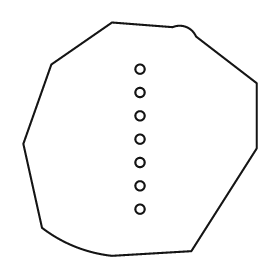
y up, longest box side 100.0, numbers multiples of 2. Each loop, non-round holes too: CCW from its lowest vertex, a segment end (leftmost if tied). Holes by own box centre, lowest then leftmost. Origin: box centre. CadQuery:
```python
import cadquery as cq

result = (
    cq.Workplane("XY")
    .moveTo(-12.0, -50.0)
    .lineTo(22.0, -48.0)
    .lineTo(50.0, -4.0)
    .lineTo(50.0, 24.0)
    .lineTo(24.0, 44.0)
    .threePointArc((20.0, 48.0), (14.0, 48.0))
    .lineTo(-12.0, 50.0)
    .lineTo(-38.0, 32.0)
    .lineTo(-50.0, -2.0)
    .lineTo(-42.0, -38.0)
    .threePointArc((-28.0, -46.0), (-12.0, -50.0))
    .close()
    .moveTo(0.0, -30.0)
    .circle(2.0)
    .moveTo(0.0, -20.0)
    .circle(2.0)
    .moveTo(0.0, -10.0)
    .circle(2.0)
    .moveTo(0.0, 0.0)
    .circle(2.0)
    .moveTo(0.0, 10.0)
    .circle(2.0)
    .moveTo(0.0, 20.0)
    .circle(2.0)
    .moveTo(0.0, 30.0)
    .circle(2.0)
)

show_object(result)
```